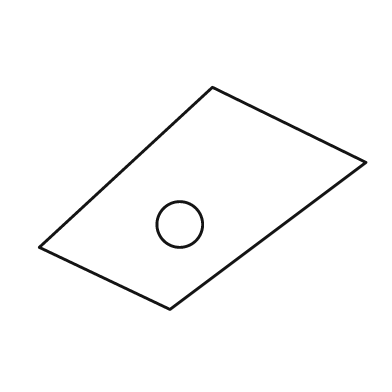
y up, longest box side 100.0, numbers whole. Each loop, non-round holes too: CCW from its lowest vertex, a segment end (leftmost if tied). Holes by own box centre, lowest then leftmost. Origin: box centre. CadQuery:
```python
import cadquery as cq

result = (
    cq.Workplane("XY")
    .moveTo(-10.0, -34.0)
    .lineTo(50.0, 11.0)
    .lineTo(3.0, 34.0)
    .lineTo(-50.0, -15.0)
    .close()
    .moveTo(-7.0, -8.0)
    .circle(7.0)
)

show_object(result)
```